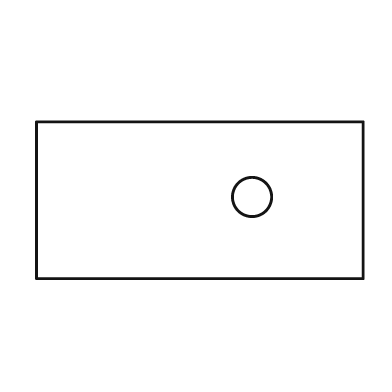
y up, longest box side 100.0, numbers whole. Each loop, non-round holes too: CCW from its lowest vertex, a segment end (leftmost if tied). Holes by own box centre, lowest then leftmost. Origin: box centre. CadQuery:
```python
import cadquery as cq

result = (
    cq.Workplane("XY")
    .moveTo(-50.0, -24.0)
    .lineTo(50.0, -24.0)
    .lineTo(50.0, 24.0)
    .lineTo(-50.0, 24.0)
    .close()
    .moveTo(16.0, 1.0)
    .circle(6.0)
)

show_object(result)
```